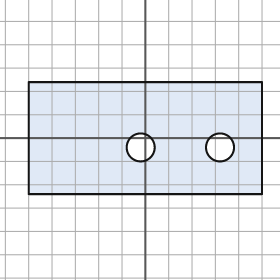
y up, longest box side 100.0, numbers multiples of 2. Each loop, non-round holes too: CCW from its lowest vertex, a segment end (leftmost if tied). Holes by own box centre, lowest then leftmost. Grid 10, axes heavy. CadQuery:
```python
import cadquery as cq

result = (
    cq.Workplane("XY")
    .moveTo(-50.0, -24.0)
    .lineTo(50.0, -24.0)
    .lineTo(50.0, 24.0)
    .lineTo(-50.0, 24.0)
    .close()
    .moveTo(-2.0, -4.0)
    .circle(6.0)
    .moveTo(32.0, -4.0)
    .circle(6.0)
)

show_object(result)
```